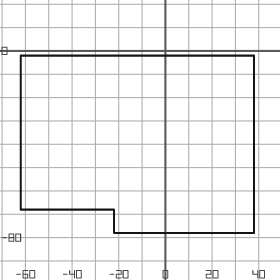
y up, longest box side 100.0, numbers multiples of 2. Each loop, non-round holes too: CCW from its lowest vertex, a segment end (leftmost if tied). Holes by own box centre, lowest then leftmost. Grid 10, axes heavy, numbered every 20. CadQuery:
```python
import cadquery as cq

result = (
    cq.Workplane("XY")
    .moveTo(-22.0, -78.0)
    .lineTo(38.0, -78.0)
    .lineTo(38.0, -2.0)
    .lineTo(-62.0, -2.0)
    .lineTo(-62.0, -68.0)
    .lineTo(-22.0, -68.0)
    .close()
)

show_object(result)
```